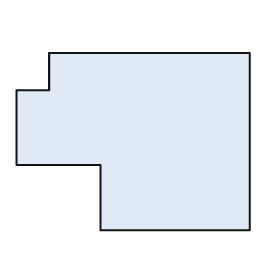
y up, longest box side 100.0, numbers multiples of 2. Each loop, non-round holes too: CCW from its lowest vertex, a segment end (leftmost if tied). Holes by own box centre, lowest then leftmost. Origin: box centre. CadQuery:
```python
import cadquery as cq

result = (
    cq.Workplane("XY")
    .moveTo(-14.0, -38.0)
    .lineTo(50.0, -38.0)
    .lineTo(50.0, 38.0)
    .lineTo(-36.0, 38.0)
    .lineTo(-36.0, 22.0)
    .lineTo(-50.0, 22.0)
    .lineTo(-50.0, -10.0)
    .lineTo(-14.0, -10.0)
    .close()
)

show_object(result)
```